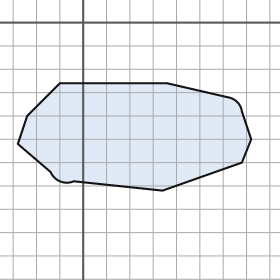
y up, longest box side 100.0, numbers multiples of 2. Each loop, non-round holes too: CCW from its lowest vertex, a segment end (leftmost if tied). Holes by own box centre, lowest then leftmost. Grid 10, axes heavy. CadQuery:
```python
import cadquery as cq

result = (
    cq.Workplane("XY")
    .moveTo(34.0, -72.0)
    .lineTo(68.0, -60.0)
    .lineTo(72.0, -50.0)
    .lineTo(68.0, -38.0)
    .threePointArc((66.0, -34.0), (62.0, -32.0))
    .lineTo(36.0, -26.0)
    .lineTo(-10.0, -26.0)
    .lineTo(-24.0, -40.0)
    .lineTo(-28.0, -52.0)
    .lineTo(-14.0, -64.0)
    .threePointArc((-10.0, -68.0), (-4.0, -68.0))
    .close()
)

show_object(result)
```